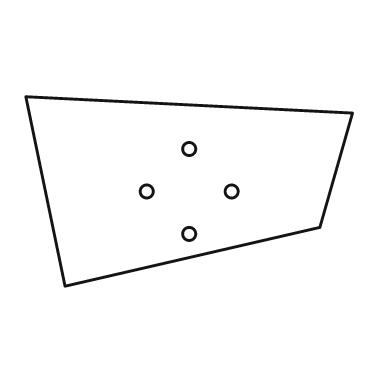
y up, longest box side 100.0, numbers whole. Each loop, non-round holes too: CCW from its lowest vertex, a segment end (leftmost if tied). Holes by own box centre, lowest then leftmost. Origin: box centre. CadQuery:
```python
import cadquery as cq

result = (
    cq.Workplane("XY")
    .moveTo(-38.0, -29.0)
    .lineTo(40.0, -11.0)
    .lineTo(50.0, 24.0)
    .lineTo(-50.0, 29.0)
    .close()
    .moveTo(0.0, -13.0)
    .circle(2.0)
    .moveTo(-13.0, 0.0)
    .circle(2.0)
    .moveTo(13.0, 0.0)
    .circle(2.0)
    .moveTo(0.0, 13.0)
    .circle(2.0)
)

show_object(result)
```